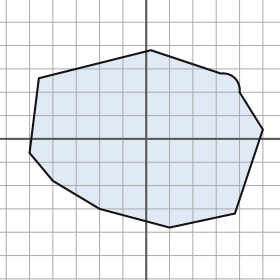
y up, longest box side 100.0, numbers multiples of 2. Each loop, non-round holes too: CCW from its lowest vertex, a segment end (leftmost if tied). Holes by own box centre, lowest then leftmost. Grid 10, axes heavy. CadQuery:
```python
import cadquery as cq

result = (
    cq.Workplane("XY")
    .moveTo(10.0, -38.0)
    .lineTo(38.0, -32.0)
    .lineTo(50.0, 4.0)
    .lineTo(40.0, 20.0)
    .threePointArc((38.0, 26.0), (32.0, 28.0))
    .lineTo(2.0, 38.0)
    .lineTo(-46.0, 26.0)
    .lineTo(-50.0, -6.0)
    .lineTo(-40.0, -18.0)
    .lineTo(-20.0, -30.0)
    .close()
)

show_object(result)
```